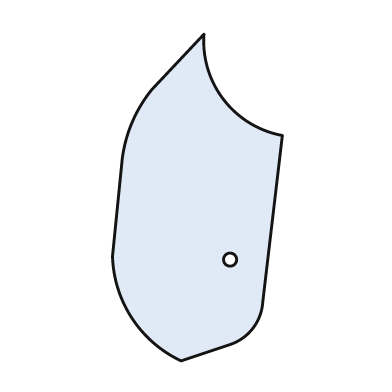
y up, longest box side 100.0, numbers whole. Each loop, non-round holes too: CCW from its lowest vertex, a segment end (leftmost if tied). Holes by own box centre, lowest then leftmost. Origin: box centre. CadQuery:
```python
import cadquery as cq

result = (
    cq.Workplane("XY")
    .moveTo(-5.0, -50.0)
    .lineTo(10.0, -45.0)
    .threePointArc((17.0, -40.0), (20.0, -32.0))
    .lineTo(26.0, 19.0)
    .threePointArc((8.0, 30.0), (2.0, 50.0))
    .lineTo(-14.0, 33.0)
    .threePointArc((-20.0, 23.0), (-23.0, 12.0))
    .lineTo(-26.0, -18.0)
    .threePointArc((-20.0, -37.0), (-5.0, -50.0))
    .close()
    .moveTo(10.0, -19.0)
    .circle(2.0)
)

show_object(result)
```